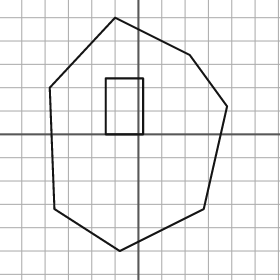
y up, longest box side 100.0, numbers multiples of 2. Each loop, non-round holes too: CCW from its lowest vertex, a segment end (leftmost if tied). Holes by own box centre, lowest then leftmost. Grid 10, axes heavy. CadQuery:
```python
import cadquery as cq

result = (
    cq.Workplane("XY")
    .moveTo(-8.0, -50.0)
    .lineTo(28.0, -32.0)
    .lineTo(38.0, 12.0)
    .lineTo(22.0, 34.0)
    .lineTo(-10.0, 50.0)
    .lineTo(-38.0, 20.0)
    .lineTo(-36.0, -32.0)
    .close()
    .moveTo(-14.0, 0.0)
    .lineTo(2.0, 0.0)
    .lineTo(2.0, 24.0)
    .lineTo(-14.0, 24.0)
    .close()
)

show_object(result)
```